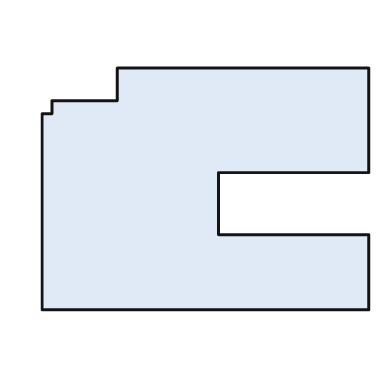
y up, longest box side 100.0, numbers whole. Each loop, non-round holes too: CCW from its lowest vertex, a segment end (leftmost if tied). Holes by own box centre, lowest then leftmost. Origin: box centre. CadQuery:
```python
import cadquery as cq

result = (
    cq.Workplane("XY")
    .moveTo(-50.0, -37.0)
    .lineTo(50.0, -37.0)
    .lineTo(50.0, -14.0)
    .lineTo(4.0, -14.0)
    .lineTo(4.0, 5.0)
    .lineTo(50.0, 5.0)
    .lineTo(50.0, 37.0)
    .lineTo(-27.0, 37.0)
    .lineTo(-27.0, 27.0)
    .lineTo(-47.0, 27.0)
    .lineTo(-47.0, 23.0)
    .lineTo(-50.0, 23.0)
    .close()
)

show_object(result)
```